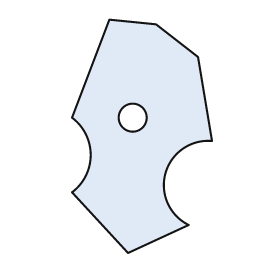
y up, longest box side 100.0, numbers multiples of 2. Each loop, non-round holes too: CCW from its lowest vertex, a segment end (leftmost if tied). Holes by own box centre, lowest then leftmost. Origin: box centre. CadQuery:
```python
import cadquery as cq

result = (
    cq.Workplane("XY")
    .moveTo(-6.0, -50.0)
    .lineTo(20.0, -38.0)
    .threePointArc((10.0, -16.0), (30.0, -2.0))
    .lineTo(24.0, 34.0)
    .lineTo(6.0, 48.0)
    .lineTo(-14.0, 50.0)
    .lineTo(-30.0, 8.0)
    .threePointArc((-22.0, -8.0), (-30.0, -24.0))
    .close()
    .moveTo(-4.0, 8.0)
    .circle(6.0)
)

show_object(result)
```